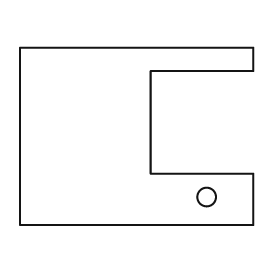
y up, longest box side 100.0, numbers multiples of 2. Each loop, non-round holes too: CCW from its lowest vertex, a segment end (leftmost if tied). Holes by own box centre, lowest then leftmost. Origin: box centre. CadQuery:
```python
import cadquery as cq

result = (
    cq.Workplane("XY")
    .moveTo(-50.0, -38.0)
    .lineTo(50.0, -38.0)
    .lineTo(50.0, -16.0)
    .lineTo(6.0, -16.0)
    .lineTo(6.0, 28.0)
    .lineTo(50.0, 28.0)
    .lineTo(50.0, 38.0)
    .lineTo(-50.0, 38.0)
    .close()
    .moveTo(30.0, -26.0)
    .circle(4.0)
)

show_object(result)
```